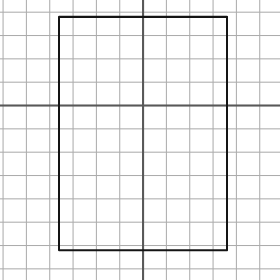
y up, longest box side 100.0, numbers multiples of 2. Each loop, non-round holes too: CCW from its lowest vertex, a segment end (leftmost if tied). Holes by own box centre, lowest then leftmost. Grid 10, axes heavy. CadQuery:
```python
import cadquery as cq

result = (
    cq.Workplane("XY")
    .moveTo(-36.0, -62.0)
    .lineTo(36.0, -62.0)
    .lineTo(36.0, 38.0)
    .lineTo(-36.0, 38.0)
    .close()
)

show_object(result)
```